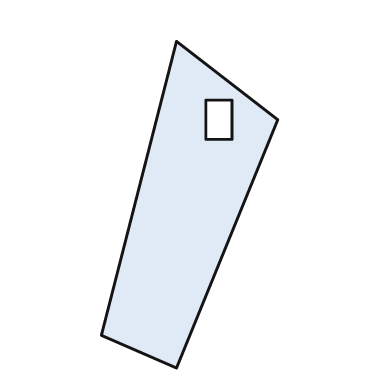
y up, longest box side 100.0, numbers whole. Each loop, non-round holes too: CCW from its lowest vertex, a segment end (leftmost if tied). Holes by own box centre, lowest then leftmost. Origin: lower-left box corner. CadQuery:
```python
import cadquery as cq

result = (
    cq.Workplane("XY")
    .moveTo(23.0, 0.0)
    .lineTo(54.0, 76.0)
    .lineTo(23.0, 100.0)
    .lineTo(0.0, 10.0)
    .close()
    .moveTo(32.0, 70.0)
    .lineTo(40.0, 70.0)
    .lineTo(40.0, 82.0)
    .lineTo(32.0, 82.0)
    .close()
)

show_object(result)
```